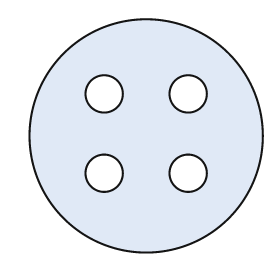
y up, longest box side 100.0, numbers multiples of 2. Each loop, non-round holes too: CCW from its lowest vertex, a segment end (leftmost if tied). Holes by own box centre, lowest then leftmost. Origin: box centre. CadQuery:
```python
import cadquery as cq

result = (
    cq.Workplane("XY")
    .moveTo(0.0, 0.0)
    .circle(50.0)
    .moveTo(-18.0, -16.0)
    .circle(8.0)
    .moveTo(18.0, -16.0)
    .circle(8.0)
    .moveTo(-18.0, 18.0)
    .circle(8.0)
    .moveTo(18.0, 18.0)
    .circle(8.0)
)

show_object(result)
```